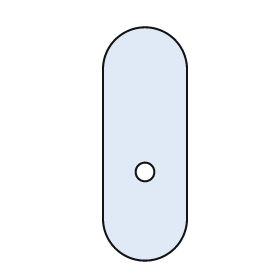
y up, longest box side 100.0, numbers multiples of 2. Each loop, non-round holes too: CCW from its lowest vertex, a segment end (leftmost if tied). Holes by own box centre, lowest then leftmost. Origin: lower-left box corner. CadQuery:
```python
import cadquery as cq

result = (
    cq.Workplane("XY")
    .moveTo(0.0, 18.0)
    .threePointArc((18.0, 0.0), (36.0, 18.0))
    .lineTo(36.0, 82.0)
    .threePointArc((18.0, 100.0), (0.0, 82.0))
    .close()
    .moveTo(18.0, 38.0)
    .circle(4.0)
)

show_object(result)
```